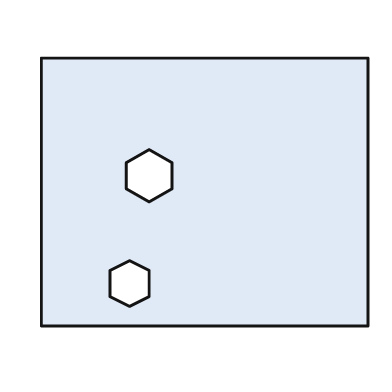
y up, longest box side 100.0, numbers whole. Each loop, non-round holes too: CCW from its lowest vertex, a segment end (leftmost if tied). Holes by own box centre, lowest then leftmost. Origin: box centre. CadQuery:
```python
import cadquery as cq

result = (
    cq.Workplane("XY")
    .moveTo(-50.0, -41.0)
    .lineTo(50.0, -41.0)
    .lineTo(50.0, 41.0)
    .lineTo(-50.0, 41.0)
    .close()
    .moveTo(-23.0, -35.0)
    .lineTo(-17.0, -32.0)
    .lineTo(-17.0, -24.0)
    .lineTo(-23.0, -21.0)
    .lineTo(-29.0, -24.0)
    .lineTo(-29.0, -32.0)
    .close()
    .moveTo(-17.0, -3.0)
    .lineTo(-10.0, 1.0)
    .lineTo(-10.0, 9.0)
    .lineTo(-17.0, 13.0)
    .lineTo(-24.0, 9.0)
    .lineTo(-24.0, 1.0)
    .close()
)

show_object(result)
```